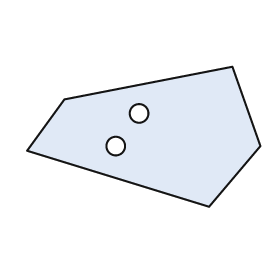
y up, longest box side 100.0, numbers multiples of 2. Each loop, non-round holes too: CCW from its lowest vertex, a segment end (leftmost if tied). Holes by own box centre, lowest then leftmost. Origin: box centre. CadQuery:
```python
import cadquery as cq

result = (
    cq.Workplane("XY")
    .moveTo(28.0, -30.0)
    .lineTo(50.0, -4.0)
    .lineTo(38.0, 30.0)
    .lineTo(-34.0, 16.0)
    .lineTo(-50.0, -6.0)
    .close()
    .moveTo(-12.0, -4.0)
    .circle(4.0)
    .moveTo(-2.0, 10.0)
    .circle(4.0)
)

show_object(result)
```